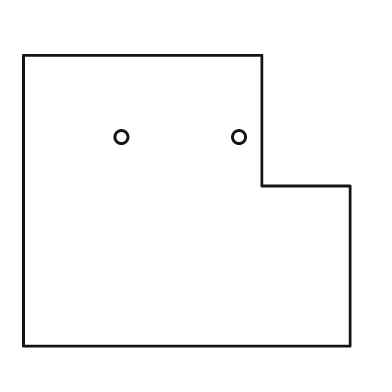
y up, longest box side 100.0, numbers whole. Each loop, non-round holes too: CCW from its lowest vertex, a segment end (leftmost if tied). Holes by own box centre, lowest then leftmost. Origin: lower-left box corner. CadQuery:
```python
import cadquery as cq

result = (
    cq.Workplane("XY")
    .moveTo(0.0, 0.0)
    .lineTo(100.0, 0.0)
    .lineTo(100.0, 49.0)
    .lineTo(73.0, 49.0)
    .lineTo(73.0, 89.0)
    .lineTo(0.0, 89.0)
    .close()
    .moveTo(30.0, 64.0)
    .circle(2.0)
    .moveTo(66.0, 64.0)
    .circle(2.0)
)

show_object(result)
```